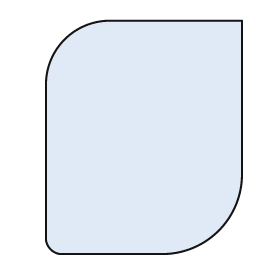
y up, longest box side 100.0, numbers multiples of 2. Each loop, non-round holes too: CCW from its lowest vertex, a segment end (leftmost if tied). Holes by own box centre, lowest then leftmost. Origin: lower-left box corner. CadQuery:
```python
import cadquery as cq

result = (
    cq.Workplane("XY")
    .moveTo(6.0, 0.0)
    .lineTo(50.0, 0.0)
    .threePointArc((74.0, 10.0), (84.0, 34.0))
    .lineTo(84.0, 100.0)
    .lineTo(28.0, 100.0)
    .threePointArc((8.0, 92.0), (0.0, 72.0))
    .lineTo(0.0, 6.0)
    .threePointArc((2.0, 2.0), (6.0, 0.0))
    .close()
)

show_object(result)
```